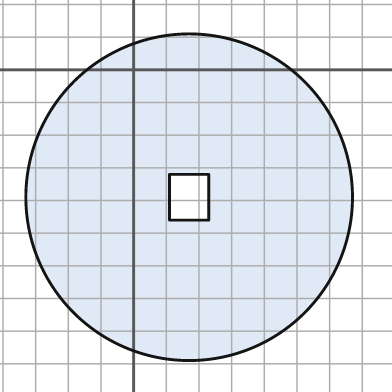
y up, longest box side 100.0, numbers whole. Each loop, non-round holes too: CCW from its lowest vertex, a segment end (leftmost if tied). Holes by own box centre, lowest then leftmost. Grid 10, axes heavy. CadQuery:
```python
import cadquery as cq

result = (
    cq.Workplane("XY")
    .moveTo(17.0, -39.0)
    .circle(50.0)
    .moveTo(11.0, -46.0)
    .lineTo(23.0, -46.0)
    .lineTo(23.0, -32.0)
    .lineTo(11.0, -32.0)
    .close()
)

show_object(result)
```